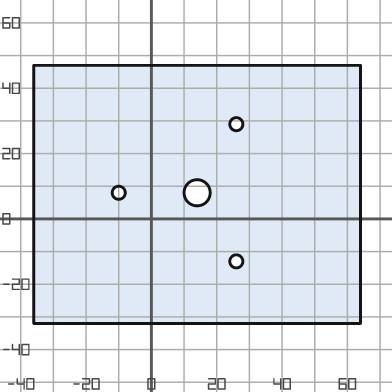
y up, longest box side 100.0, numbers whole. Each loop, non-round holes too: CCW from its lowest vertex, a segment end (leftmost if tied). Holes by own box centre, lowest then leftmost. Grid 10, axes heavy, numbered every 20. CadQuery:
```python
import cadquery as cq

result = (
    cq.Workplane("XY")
    .moveTo(-36.0, -32.0)
    .lineTo(64.0, -32.0)
    .lineTo(64.0, 47.0)
    .lineTo(-36.0, 47.0)
    .close()
    .moveTo(26.0, -13.0)
    .circle(2.0)
    .moveTo(-10.0, 8.0)
    .circle(2.0)
    .moveTo(14.0, 8.0)
    .circle(4.0)
    .moveTo(26.0, 29.0)
    .circle(2.0)
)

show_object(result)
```